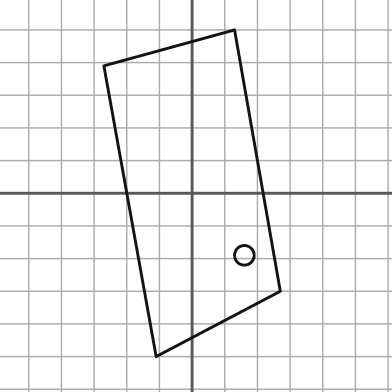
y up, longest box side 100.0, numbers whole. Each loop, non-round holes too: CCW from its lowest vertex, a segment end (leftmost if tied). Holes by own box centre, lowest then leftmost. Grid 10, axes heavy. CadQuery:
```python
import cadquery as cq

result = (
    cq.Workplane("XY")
    .moveTo(-11.0, -50.0)
    .lineTo(27.0, -30.0)
    .lineTo(13.0, 50.0)
    .lineTo(-27.0, 39.0)
    .close()
    .moveTo(16.0, -19.0)
    .circle(3.0)
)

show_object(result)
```